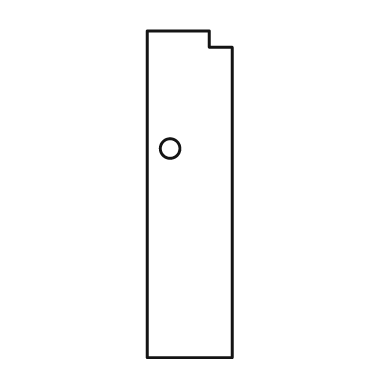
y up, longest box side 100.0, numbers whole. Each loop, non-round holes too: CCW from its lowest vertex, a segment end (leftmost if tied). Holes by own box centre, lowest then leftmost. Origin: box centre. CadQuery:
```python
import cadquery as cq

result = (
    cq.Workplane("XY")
    .moveTo(-13.0, -50.0)
    .lineTo(13.0, -50.0)
    .lineTo(13.0, 45.0)
    .lineTo(6.0, 45.0)
    .lineTo(6.0, 50.0)
    .lineTo(-13.0, 50.0)
    .close()
    .moveTo(-6.0, 14.0)
    .circle(3.0)
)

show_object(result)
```